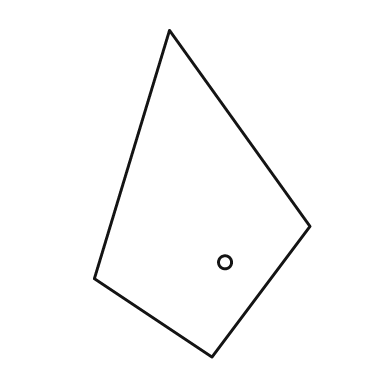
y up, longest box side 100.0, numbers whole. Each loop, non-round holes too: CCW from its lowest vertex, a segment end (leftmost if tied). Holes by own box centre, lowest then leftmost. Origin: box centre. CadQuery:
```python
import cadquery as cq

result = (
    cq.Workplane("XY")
    .moveTo(3.0, -50.0)
    .lineTo(33.0, -10.0)
    .lineTo(-10.0, 50.0)
    .lineTo(-33.0, -26.0)
    .close()
    .moveTo(7.0, -21.0)
    .circle(2.0)
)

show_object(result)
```